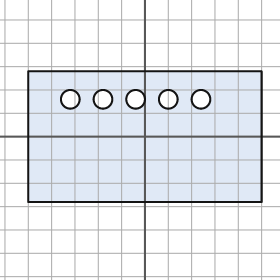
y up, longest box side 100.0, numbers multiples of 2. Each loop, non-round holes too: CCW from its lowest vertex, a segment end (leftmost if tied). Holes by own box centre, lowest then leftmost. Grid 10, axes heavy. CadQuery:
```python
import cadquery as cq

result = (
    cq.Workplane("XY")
    .moveTo(-50.0, -28.0)
    .lineTo(50.0, -28.0)
    .lineTo(50.0, 28.0)
    .lineTo(-50.0, 28.0)
    .close()
    .moveTo(-32.0, 16.0)
    .circle(4.0)
    .moveTo(-18.0, 16.0)
    .circle(4.0)
    .moveTo(-4.0, 16.0)
    .circle(4.0)
    .moveTo(10.0, 16.0)
    .circle(4.0)
    .moveTo(24.0, 16.0)
    .circle(4.0)
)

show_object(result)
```